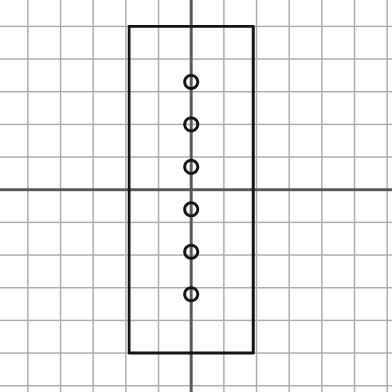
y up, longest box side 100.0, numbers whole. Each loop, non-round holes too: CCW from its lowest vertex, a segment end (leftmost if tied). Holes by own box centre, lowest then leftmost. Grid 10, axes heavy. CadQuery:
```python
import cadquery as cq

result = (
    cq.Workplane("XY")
    .moveTo(-19.0, -50.0)
    .lineTo(19.0, -50.0)
    .lineTo(19.0, 50.0)
    .lineTo(-19.0, 50.0)
    .close()
    .moveTo(0.0, -32.0)
    .circle(2.0)
    .moveTo(0.0, -19.0)
    .circle(2.0)
    .moveTo(0.0, -6.0)
    .circle(2.0)
    .moveTo(0.0, 7.0)
    .circle(2.0)
    .moveTo(0.0, 20.0)
    .circle(2.0)
    .moveTo(0.0, 33.0)
    .circle(2.0)
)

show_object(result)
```